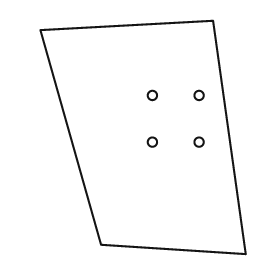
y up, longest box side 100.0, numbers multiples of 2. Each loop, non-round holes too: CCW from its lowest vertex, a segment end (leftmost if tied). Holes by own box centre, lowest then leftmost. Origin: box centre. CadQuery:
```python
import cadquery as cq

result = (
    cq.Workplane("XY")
    .moveTo(44.0, -50.0)
    .lineTo(30.0, 50.0)
    .lineTo(-44.0, 46.0)
    .lineTo(-18.0, -46.0)
    .close()
    .moveTo(4.0, -2.0)
    .circle(2.0)
    .moveTo(24.0, -2.0)
    .circle(2.0)
    .moveTo(4.0, 18.0)
    .circle(2.0)
    .moveTo(24.0, 18.0)
    .circle(2.0)
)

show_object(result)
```